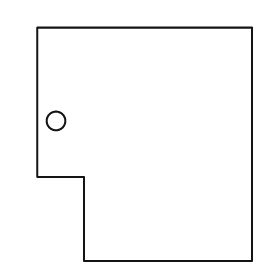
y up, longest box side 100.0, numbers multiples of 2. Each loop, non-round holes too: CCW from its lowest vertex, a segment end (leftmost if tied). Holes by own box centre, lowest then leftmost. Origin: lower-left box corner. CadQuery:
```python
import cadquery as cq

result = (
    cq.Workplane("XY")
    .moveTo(20.0, 0.0)
    .lineTo(92.0, 0.0)
    .lineTo(92.0, 100.0)
    .lineTo(0.0, 100.0)
    .lineTo(0.0, 36.0)
    .lineTo(20.0, 36.0)
    .close()
    .moveTo(8.0, 60.0)
    .circle(4.0)
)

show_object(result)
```